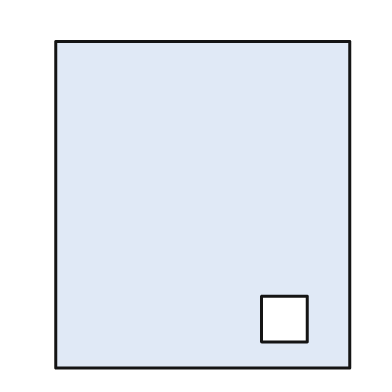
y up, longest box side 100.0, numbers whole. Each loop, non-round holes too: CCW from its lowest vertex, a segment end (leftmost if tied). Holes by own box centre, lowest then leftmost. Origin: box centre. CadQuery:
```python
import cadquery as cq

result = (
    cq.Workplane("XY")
    .moveTo(-45.0, -50.0)
    .lineTo(45.0, -50.0)
    .lineTo(45.0, 50.0)
    .lineTo(-45.0, 50.0)
    .close()
    .moveTo(18.0, -42.0)
    .lineTo(32.0, -42.0)
    .lineTo(32.0, -28.0)
    .lineTo(18.0, -28.0)
    .close()
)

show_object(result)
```